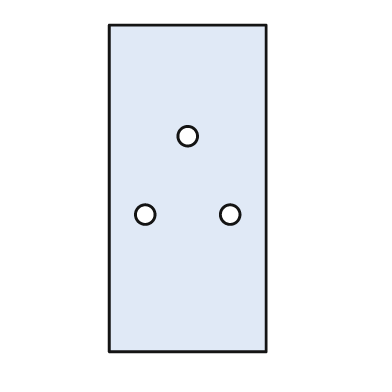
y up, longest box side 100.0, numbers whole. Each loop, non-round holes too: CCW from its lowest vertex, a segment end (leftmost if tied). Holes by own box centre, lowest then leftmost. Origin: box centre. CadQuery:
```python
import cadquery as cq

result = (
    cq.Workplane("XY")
    .moveTo(-24.0, -50.0)
    .lineTo(24.0, -50.0)
    .lineTo(24.0, 50.0)
    .lineTo(-24.0, 50.0)
    .close()
    .moveTo(-13.0, -8.0)
    .circle(3.0)
    .moveTo(13.0, -8.0)
    .circle(3.0)
    .moveTo(0.0, 16.0)
    .circle(3.0)
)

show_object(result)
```